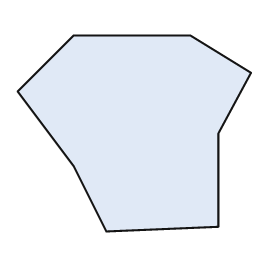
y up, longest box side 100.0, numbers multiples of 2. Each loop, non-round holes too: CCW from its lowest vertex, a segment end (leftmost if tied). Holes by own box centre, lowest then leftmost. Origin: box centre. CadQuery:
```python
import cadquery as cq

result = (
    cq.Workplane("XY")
    .moveTo(-12.0, -42.0)
    .lineTo(36.0, -40.0)
    .lineTo(36.0, 0.0)
    .lineTo(50.0, 26.0)
    .lineTo(24.0, 42.0)
    .lineTo(-26.0, 42.0)
    .lineTo(-50.0, 18.0)
    .lineTo(-26.0, -14.0)
    .close()
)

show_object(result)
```